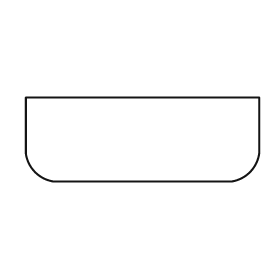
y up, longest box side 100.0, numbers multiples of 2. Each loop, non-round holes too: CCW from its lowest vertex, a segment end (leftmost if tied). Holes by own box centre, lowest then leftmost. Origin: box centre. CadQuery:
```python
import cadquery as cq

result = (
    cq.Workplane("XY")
    .moveTo(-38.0, -18.0)
    .lineTo(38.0, -18.0)
    .threePointArc((46.0, -14.0), (50.0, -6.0))
    .lineTo(50.0, 18.0)
    .lineTo(-50.0, 18.0)
    .lineTo(-50.0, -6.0)
    .threePointArc((-46.0, -14.0), (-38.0, -18.0))
    .close()
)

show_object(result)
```